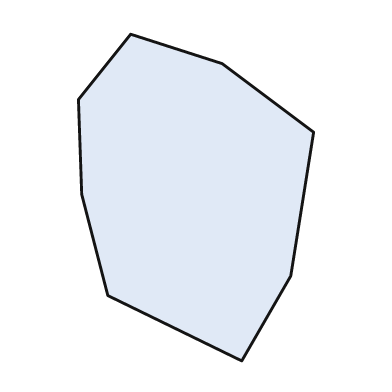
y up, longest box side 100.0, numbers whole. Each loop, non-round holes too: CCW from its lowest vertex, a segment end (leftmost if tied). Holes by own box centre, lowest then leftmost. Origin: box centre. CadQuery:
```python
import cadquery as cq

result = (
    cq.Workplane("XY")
    .moveTo(14.0, -50.0)
    .lineTo(29.0, -24.0)
    .lineTo(36.0, 20.0)
    .lineTo(8.0, 41.0)
    .lineTo(-20.0, 50.0)
    .lineTo(-36.0, 30.0)
    .lineTo(-35.0, 1.0)
    .lineTo(-27.0, -30.0)
    .close()
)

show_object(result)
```